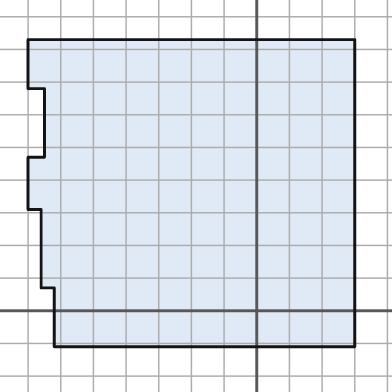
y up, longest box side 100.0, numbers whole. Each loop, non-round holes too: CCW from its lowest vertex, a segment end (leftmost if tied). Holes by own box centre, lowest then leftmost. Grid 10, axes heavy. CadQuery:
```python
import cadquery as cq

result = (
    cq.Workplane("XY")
    .moveTo(-62.0, -11.0)
    .lineTo(30.0, -11.0)
    .lineTo(30.0, 83.0)
    .lineTo(-70.0, 83.0)
    .lineTo(-70.0, 68.0)
    .lineTo(-65.0, 68.0)
    .lineTo(-65.0, 47.0)
    .lineTo(-70.0, 47.0)
    .lineTo(-70.0, 31.0)
    .lineTo(-66.0, 31.0)
    .lineTo(-66.0, 7.0)
    .lineTo(-62.0, 7.0)
    .close()
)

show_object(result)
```